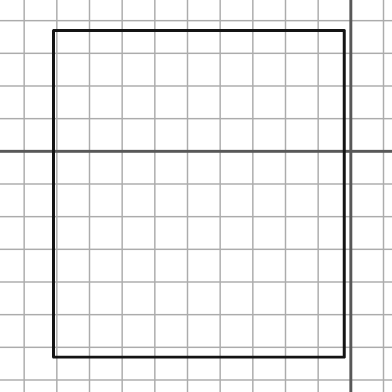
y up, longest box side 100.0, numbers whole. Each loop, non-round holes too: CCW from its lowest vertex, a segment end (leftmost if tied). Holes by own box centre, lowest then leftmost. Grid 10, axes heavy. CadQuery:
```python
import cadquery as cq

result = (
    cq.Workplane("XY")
    .moveTo(-91.0, -63.0)
    .lineTo(-2.0, -63.0)
    .lineTo(-2.0, 37.0)
    .lineTo(-91.0, 37.0)
    .close()
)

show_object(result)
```